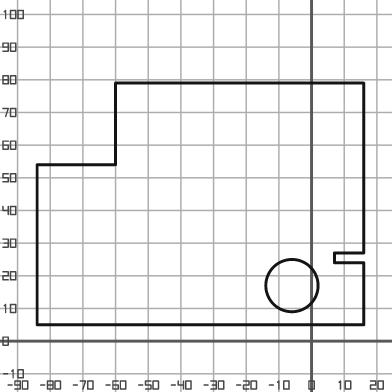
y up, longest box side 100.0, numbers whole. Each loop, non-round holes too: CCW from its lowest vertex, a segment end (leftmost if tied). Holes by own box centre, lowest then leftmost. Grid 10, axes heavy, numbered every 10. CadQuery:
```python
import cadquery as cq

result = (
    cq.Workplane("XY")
    .moveTo(-84.0, 5.0)
    .lineTo(16.0, 5.0)
    .lineTo(16.0, 24.0)
    .lineTo(7.0, 24.0)
    .lineTo(7.0, 27.0)
    .lineTo(16.0, 27.0)
    .lineTo(16.0, 79.0)
    .lineTo(-60.0, 79.0)
    .lineTo(-60.0, 54.0)
    .lineTo(-84.0, 54.0)
    .close()
    .moveTo(-6.0, 17.0)
    .circle(8.0)
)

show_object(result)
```